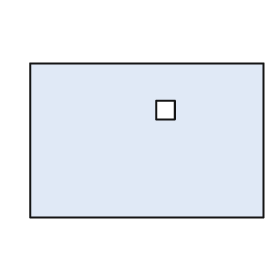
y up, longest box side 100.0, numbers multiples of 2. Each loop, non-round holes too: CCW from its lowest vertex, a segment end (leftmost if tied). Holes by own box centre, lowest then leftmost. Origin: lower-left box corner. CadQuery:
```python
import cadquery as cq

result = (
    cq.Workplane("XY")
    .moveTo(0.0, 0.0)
    .lineTo(100.0, 0.0)
    .lineTo(100.0, 66.0)
    .lineTo(0.0, 66.0)
    .close()
    .moveTo(54.0, 42.0)
    .lineTo(62.0, 42.0)
    .lineTo(62.0, 50.0)
    .lineTo(54.0, 50.0)
    .close()
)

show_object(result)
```